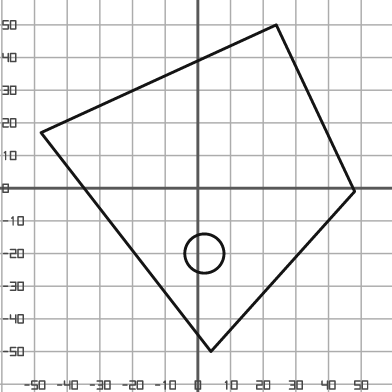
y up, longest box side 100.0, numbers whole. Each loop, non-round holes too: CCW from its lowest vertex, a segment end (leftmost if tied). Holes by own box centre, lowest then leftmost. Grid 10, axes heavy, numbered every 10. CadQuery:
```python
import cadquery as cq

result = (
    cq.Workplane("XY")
    .moveTo(4.0, -50.0)
    .lineTo(48.0, -1.0)
    .lineTo(24.0, 50.0)
    .lineTo(-48.0, 17.0)
    .close()
    .moveTo(2.0, -20.0)
    .circle(6.0)
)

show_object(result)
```